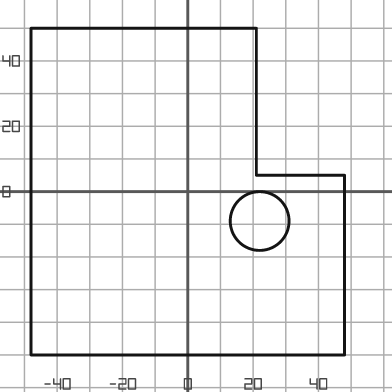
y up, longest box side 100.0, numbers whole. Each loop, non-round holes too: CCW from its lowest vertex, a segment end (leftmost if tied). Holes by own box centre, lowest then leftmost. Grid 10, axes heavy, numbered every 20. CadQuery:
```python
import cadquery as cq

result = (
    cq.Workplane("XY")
    .moveTo(-48.0, -50.0)
    .lineTo(48.0, -50.0)
    .lineTo(48.0, 5.0)
    .lineTo(21.0, 5.0)
    .lineTo(21.0, 50.0)
    .lineTo(-48.0, 50.0)
    .close()
    .moveTo(22.0, -9.0)
    .circle(9.0)
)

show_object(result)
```